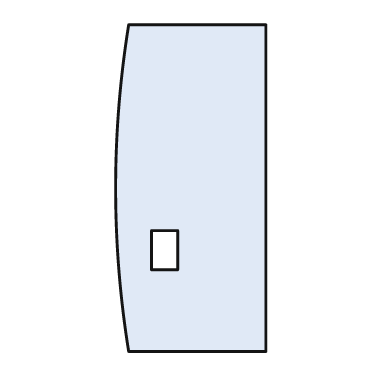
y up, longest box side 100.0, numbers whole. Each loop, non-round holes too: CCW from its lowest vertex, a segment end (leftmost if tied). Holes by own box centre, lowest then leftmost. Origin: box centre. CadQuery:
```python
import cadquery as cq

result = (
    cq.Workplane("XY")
    .moveTo(-19.0, -50.0)
    .lineTo(23.0, -50.0)
    .lineTo(23.0, 50.0)
    .lineTo(-19.0, 50.0)
    .threePointArc((-23.0, 0.0), (-19.0, -50.0))
    .close()
    .moveTo(-12.0, -25.0)
    .lineTo(-4.0, -25.0)
    .lineTo(-4.0, -13.0)
    .lineTo(-12.0, -13.0)
    .close()
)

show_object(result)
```